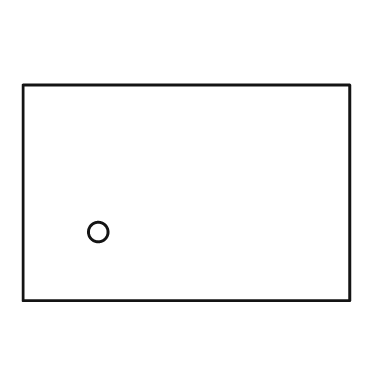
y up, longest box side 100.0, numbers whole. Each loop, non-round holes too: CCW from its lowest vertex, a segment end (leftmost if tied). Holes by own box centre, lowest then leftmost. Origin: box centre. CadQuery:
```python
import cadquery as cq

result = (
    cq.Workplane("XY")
    .moveTo(-50.0, -33.0)
    .lineTo(50.0, -33.0)
    .lineTo(50.0, 33.0)
    .lineTo(-50.0, 33.0)
    .close()
    .moveTo(-27.0, -12.0)
    .circle(3.0)
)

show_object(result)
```